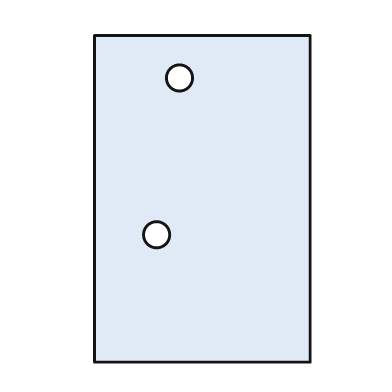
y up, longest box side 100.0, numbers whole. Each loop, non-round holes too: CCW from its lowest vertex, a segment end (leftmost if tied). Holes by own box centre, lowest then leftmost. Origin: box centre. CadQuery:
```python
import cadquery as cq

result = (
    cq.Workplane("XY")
    .moveTo(-33.0, -50.0)
    .lineTo(33.0, -50.0)
    .lineTo(33.0, 50.0)
    .lineTo(-33.0, 50.0)
    .close()
    .moveTo(-14.0, -11.0)
    .circle(4.0)
    .moveTo(-7.0, 37.0)
    .circle(4.0)
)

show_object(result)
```